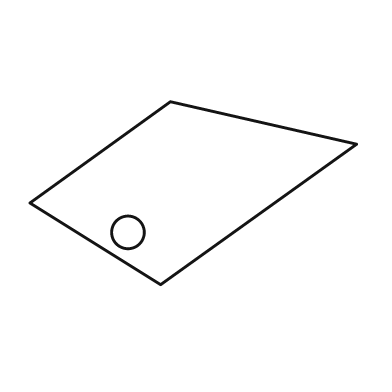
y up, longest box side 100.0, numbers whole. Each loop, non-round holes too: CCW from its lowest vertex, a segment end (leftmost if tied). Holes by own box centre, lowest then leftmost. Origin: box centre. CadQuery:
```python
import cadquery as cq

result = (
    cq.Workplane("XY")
    .moveTo(-10.0, -28.0)
    .lineTo(50.0, 15.0)
    .lineTo(-7.0, 28.0)
    .lineTo(-50.0, -3.0)
    .close()
    .moveTo(-20.0, -12.0)
    .circle(5.0)
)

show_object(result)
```